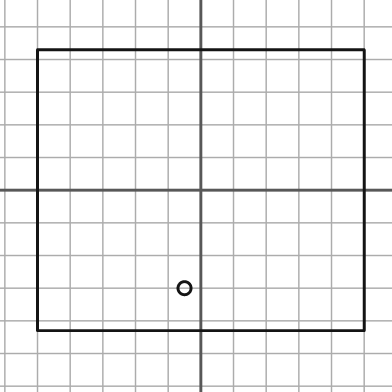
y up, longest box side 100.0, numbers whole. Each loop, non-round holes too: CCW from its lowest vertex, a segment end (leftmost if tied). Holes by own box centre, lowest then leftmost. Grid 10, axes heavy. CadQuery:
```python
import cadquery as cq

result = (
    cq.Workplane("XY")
    .moveTo(-50.0, -43.0)
    .lineTo(50.0, -43.0)
    .lineTo(50.0, 43.0)
    .lineTo(-50.0, 43.0)
    .close()
    .moveTo(-5.0, -30.0)
    .circle(2.0)
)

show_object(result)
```